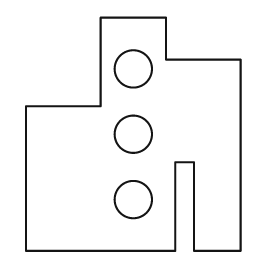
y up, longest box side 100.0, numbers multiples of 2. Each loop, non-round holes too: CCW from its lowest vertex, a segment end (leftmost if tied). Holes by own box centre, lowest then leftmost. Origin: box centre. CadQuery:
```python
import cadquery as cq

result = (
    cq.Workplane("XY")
    .moveTo(-46.0, -50.0)
    .lineTo(18.0, -50.0)
    .lineTo(18.0, -12.0)
    .lineTo(26.0, -12.0)
    .lineTo(26.0, -50.0)
    .lineTo(46.0, -50.0)
    .lineTo(46.0, 32.0)
    .lineTo(14.0, 32.0)
    .lineTo(14.0, 50.0)
    .lineTo(-14.0, 50.0)
    .lineTo(-14.0, 12.0)
    .lineTo(-46.0, 12.0)
    .close()
    .moveTo(0.0, -28.0)
    .circle(8.0)
    .moveTo(0.0, 0.0)
    .circle(8.0)
    .moveTo(0.0, 28.0)
    .circle(8.0)
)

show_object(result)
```